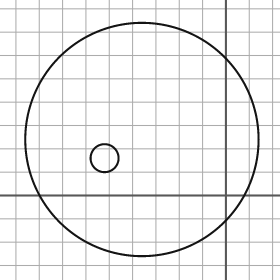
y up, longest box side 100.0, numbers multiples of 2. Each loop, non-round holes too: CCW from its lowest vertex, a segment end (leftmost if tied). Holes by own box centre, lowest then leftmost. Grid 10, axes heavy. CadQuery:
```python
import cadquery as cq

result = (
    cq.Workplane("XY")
    .moveTo(-36.0, 24.0)
    .circle(50.0)
    .moveTo(-52.0, 16.0)
    .circle(6.0)
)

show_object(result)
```